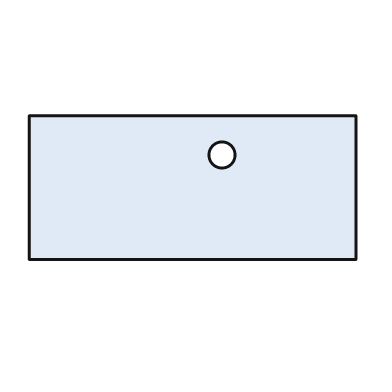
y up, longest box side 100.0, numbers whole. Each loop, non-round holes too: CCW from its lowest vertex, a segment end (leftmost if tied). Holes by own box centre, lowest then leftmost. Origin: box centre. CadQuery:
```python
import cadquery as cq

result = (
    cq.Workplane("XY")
    .moveTo(-50.0, -22.0)
    .lineTo(50.0, -22.0)
    .lineTo(50.0, 22.0)
    .lineTo(-50.0, 22.0)
    .close()
    .moveTo(9.0, 10.0)
    .circle(4.0)
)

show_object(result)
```